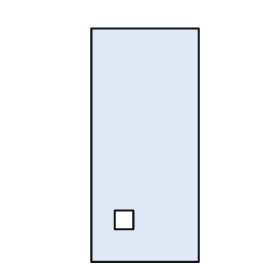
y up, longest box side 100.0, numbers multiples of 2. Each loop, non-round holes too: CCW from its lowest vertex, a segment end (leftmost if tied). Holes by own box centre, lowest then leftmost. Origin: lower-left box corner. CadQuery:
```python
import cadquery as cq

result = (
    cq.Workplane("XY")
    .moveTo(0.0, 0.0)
    .lineTo(46.0, 0.0)
    .lineTo(46.0, 100.0)
    .lineTo(0.0, 100.0)
    .close()
    .moveTo(10.0, 14.0)
    .lineTo(18.0, 14.0)
    .lineTo(18.0, 22.0)
    .lineTo(10.0, 22.0)
    .close()
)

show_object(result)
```